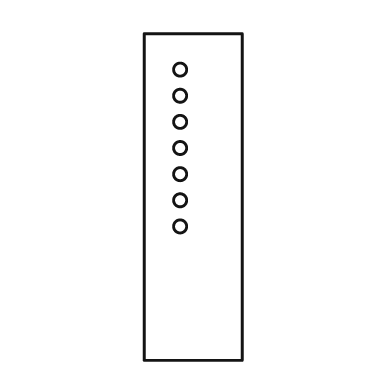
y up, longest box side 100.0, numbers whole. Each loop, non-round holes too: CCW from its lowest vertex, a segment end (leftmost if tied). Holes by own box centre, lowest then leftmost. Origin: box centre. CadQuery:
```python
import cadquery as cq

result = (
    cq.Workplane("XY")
    .moveTo(-15.0, -50.0)
    .lineTo(15.0, -50.0)
    .lineTo(15.0, 50.0)
    .lineTo(-15.0, 50.0)
    .close()
    .moveTo(-4.0, -9.0)
    .circle(2.0)
    .moveTo(-4.0, -1.0)
    .circle(2.0)
    .moveTo(-4.0, 7.0)
    .circle(2.0)
    .moveTo(-4.0, 15.0)
    .circle(2.0)
    .moveTo(-4.0, 23.0)
    .circle(2.0)
    .moveTo(-4.0, 31.0)
    .circle(2.0)
    .moveTo(-4.0, 39.0)
    .circle(2.0)
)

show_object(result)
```